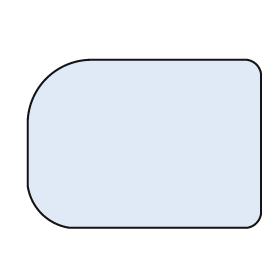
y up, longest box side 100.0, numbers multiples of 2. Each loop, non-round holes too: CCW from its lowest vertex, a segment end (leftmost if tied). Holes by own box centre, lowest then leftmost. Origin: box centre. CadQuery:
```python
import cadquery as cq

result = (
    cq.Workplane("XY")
    .moveTo(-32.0, -36.0)
    .lineTo(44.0, -36.0)
    .threePointArc((48.0, -34.0), (50.0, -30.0))
    .lineTo(50.0, 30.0)
    .threePointArc((48.0, 34.0), (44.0, 36.0))
    .lineTo(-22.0, 36.0)
    .threePointArc((-42.0, 28.0), (-50.0, 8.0))
    .lineTo(-50.0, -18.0)
    .threePointArc((-44.0, -30.0), (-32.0, -36.0))
    .close()
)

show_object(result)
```